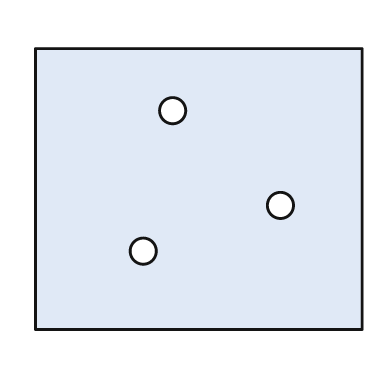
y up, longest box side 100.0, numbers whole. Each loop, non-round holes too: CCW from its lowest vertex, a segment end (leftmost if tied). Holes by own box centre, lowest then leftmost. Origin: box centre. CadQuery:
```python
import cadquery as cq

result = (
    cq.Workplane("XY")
    .moveTo(-50.0, -43.0)
    .lineTo(50.0, -43.0)
    .lineTo(50.0, 43.0)
    .lineTo(-50.0, 43.0)
    .close()
    .moveTo(-17.0, -19.0)
    .circle(4.0)
    .moveTo(25.0, -5.0)
    .circle(4.0)
    .moveTo(-8.0, 24.0)
    .circle(4.0)
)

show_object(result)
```